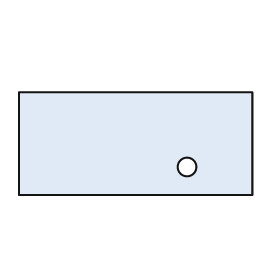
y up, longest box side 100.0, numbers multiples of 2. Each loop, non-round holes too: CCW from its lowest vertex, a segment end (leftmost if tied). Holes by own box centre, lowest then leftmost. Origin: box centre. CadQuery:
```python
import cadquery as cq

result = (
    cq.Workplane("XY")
    .moveTo(-50.0, -22.0)
    .lineTo(50.0, -22.0)
    .lineTo(50.0, 22.0)
    .lineTo(-50.0, 22.0)
    .close()
    .moveTo(22.0, -10.0)
    .circle(4.0)
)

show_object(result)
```